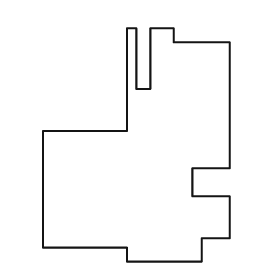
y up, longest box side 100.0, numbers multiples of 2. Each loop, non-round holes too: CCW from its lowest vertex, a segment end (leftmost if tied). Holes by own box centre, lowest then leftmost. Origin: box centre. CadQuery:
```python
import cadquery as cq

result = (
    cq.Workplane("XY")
    .moveTo(-4.0, -50.0)
    .lineTo(28.0, -50.0)
    .lineTo(28.0, -40.0)
    .lineTo(40.0, -40.0)
    .lineTo(40.0, -22.0)
    .lineTo(24.0, -22.0)
    .lineTo(24.0, -10.0)
    .lineTo(40.0, -10.0)
    .lineTo(40.0, 44.0)
    .lineTo(16.0, 44.0)
    .lineTo(16.0, 50.0)
    .lineTo(6.0, 50.0)
    .lineTo(6.0, 24.0)
    .lineTo(0.0, 24.0)
    .lineTo(0.0, 50.0)
    .lineTo(-4.0, 50.0)
    .lineTo(-4.0, 6.0)
    .lineTo(-40.0, 6.0)
    .lineTo(-40.0, -44.0)
    .lineTo(-4.0, -44.0)
    .close()
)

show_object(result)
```